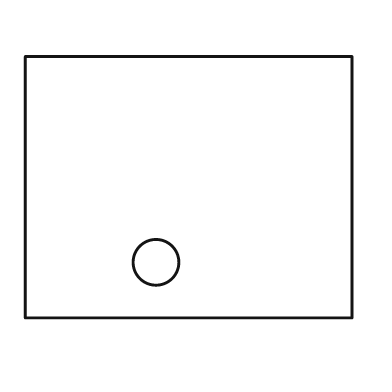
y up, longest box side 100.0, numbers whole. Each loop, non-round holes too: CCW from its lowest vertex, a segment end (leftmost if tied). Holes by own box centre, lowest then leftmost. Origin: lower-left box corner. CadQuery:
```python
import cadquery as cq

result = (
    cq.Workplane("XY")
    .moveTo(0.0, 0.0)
    .lineTo(100.0, 0.0)
    .lineTo(100.0, 80.0)
    .lineTo(0.0, 80.0)
    .close()
    .moveTo(40.0, 17.0)
    .circle(7.0)
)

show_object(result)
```